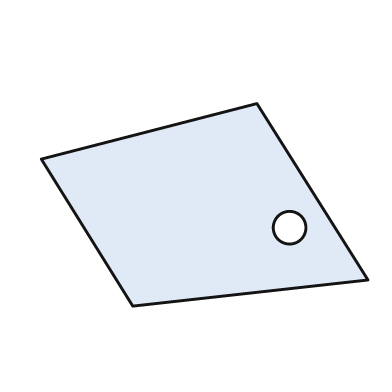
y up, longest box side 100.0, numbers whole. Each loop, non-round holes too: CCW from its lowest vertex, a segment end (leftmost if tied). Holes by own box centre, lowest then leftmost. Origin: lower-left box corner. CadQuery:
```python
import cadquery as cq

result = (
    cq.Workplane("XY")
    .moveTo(28.0, 0.0)
    .lineTo(100.0, 8.0)
    .lineTo(66.0, 62.0)
    .lineTo(0.0, 45.0)
    .close()
    .moveTo(76.0, 24.0)
    .circle(5.0)
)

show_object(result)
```